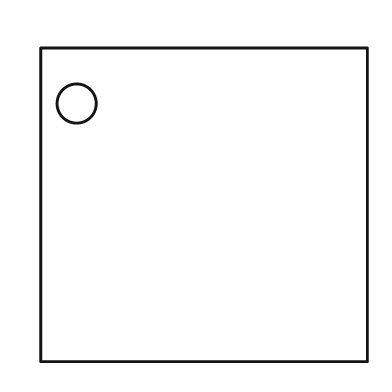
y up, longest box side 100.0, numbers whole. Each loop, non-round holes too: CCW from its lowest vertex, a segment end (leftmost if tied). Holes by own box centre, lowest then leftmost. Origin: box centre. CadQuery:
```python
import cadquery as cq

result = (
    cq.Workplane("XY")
    .moveTo(-50.0, -48.0)
    .lineTo(50.0, -48.0)
    .lineTo(50.0, 48.0)
    .lineTo(-50.0, 48.0)
    .close()
    .moveTo(-39.0, 31.0)
    .circle(6.0)
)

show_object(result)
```